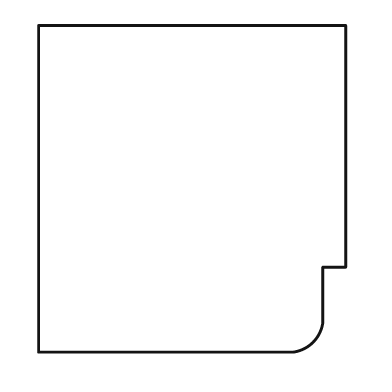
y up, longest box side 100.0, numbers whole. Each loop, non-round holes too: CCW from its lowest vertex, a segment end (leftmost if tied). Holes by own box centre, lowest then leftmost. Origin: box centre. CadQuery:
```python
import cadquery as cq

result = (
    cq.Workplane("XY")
    .moveTo(-47.0, -50.0)
    .lineTo(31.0, -50.0)
    .threePointArc((37.0, -47.0), (40.0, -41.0))
    .lineTo(40.0, -24.0)
    .lineTo(47.0, -24.0)
    .lineTo(47.0, 50.0)
    .lineTo(-47.0, 50.0)
    .close()
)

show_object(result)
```